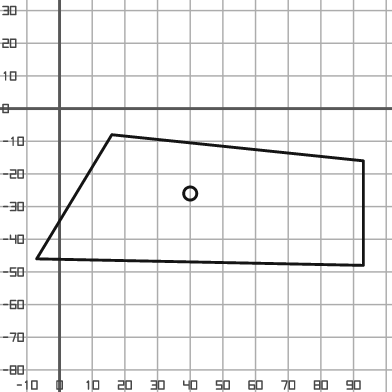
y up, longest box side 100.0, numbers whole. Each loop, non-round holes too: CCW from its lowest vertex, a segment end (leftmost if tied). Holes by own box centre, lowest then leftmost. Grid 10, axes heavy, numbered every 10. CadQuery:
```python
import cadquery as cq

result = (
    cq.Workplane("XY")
    .moveTo(93.0, -48.0)
    .lineTo(93.0, -16.0)
    .lineTo(16.0, -8.0)
    .lineTo(-7.0, -46.0)
    .close()
    .moveTo(40.0, -26.0)
    .circle(2.0)
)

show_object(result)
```